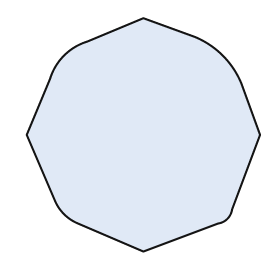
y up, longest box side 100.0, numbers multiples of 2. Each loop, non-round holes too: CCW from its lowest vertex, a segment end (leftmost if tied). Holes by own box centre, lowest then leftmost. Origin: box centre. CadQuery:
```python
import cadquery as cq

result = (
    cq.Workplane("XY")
    .moveTo(0.0, -50.0)
    .lineTo(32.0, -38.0)
    .threePointArc((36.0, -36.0), (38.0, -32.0))
    .lineTo(50.0, 0.0)
    .lineTo(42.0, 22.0)
    .threePointArc((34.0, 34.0), (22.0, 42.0))
    .lineTo(0.0, 50.0)
    .lineTo(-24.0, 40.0)
    .threePointArc((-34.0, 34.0), (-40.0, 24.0))
    .lineTo(-50.0, 0.0)
    .lineTo(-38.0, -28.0)
    .threePointArc((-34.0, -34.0), (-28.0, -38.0))
    .close()
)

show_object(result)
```